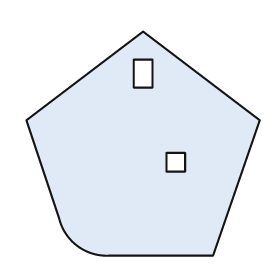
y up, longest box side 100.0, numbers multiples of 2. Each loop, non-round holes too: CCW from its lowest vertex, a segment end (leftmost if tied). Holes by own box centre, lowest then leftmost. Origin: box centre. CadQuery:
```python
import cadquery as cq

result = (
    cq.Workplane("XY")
    .moveTo(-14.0, -48.0)
    .lineTo(30.0, -48.0)
    .lineTo(50.0, 10.0)
    .lineTo(0.0, 48.0)
    .lineTo(-50.0, 10.0)
    .lineTo(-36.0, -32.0)
    .threePointArc((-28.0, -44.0), (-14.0, -48.0))
    .close()
    .moveTo(10.0, -12.0)
    .lineTo(18.0, -12.0)
    .lineTo(18.0, -4.0)
    .lineTo(10.0, -4.0)
    .close()
    .moveTo(-4.0, 24.0)
    .lineTo(4.0, 24.0)
    .lineTo(4.0, 36.0)
    .lineTo(-4.0, 36.0)
    .close()
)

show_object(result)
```